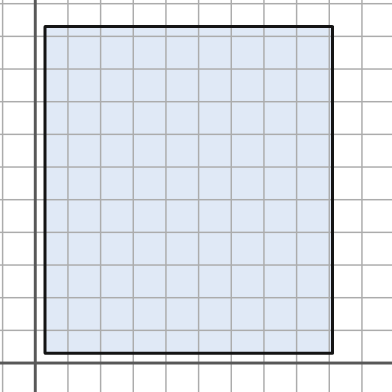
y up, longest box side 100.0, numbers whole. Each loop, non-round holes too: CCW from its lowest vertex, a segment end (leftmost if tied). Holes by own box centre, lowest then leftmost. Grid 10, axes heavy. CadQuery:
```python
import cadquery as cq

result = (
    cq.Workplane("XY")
    .moveTo(3.0, 3.0)
    .lineTo(91.0, 3.0)
    .lineTo(91.0, 103.0)
    .lineTo(3.0, 103.0)
    .close()
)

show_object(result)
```